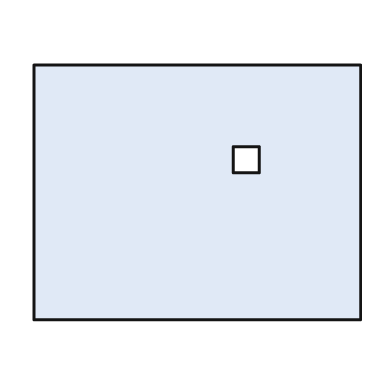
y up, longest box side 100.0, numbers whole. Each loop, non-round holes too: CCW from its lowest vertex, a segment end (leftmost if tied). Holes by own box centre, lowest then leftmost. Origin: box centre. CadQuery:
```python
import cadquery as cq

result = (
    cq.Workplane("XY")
    .moveTo(-50.0, -39.0)
    .lineTo(50.0, -39.0)
    .lineTo(50.0, 39.0)
    .lineTo(-50.0, 39.0)
    .close()
    .moveTo(11.0, 6.0)
    .lineTo(19.0, 6.0)
    .lineTo(19.0, 14.0)
    .lineTo(11.0, 14.0)
    .close()
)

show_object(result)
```